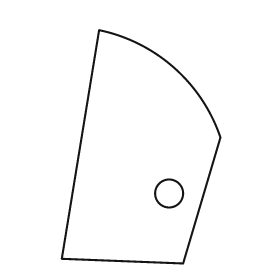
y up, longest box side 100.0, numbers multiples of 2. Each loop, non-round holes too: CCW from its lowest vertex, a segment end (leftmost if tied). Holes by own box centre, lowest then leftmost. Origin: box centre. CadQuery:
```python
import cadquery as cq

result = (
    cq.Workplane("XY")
    .moveTo(18.0, -50.0)
    .lineTo(34.0, 4.0)
    .threePointArc((14.0, 34.0), (-18.0, 50.0))
    .lineTo(-34.0, -48.0)
    .close()
    .moveTo(12.0, -20.0)
    .circle(6.0)
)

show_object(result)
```